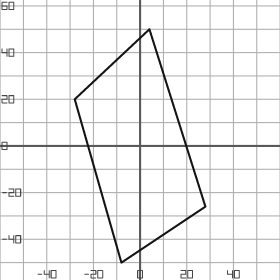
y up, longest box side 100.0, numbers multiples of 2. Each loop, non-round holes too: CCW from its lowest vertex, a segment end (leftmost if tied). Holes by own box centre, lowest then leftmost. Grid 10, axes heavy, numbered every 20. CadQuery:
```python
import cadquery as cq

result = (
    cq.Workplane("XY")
    .moveTo(-8.0, -50.0)
    .lineTo(28.0, -26.0)
    .lineTo(4.0, 50.0)
    .lineTo(-28.0, 20.0)
    .close()
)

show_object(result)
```